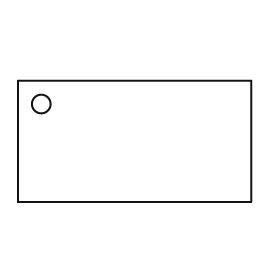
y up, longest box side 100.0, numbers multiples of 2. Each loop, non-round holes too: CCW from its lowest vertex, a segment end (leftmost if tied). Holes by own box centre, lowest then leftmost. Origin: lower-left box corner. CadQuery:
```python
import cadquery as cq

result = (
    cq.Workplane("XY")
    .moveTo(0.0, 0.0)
    .lineTo(100.0, 0.0)
    .lineTo(100.0, 52.0)
    .lineTo(0.0, 52.0)
    .close()
    .moveTo(10.0, 42.0)
    .circle(4.0)
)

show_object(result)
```